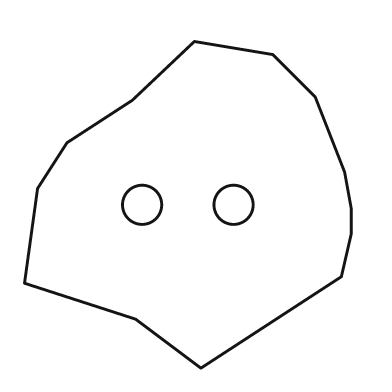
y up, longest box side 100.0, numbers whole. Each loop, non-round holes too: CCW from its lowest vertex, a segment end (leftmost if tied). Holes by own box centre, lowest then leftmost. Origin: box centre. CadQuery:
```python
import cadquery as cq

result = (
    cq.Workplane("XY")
    .moveTo(4.0, -50.0)
    .lineTo(47.0, -22.0)
    .lineTo(50.0, -9.0)
    .lineTo(50.0, -1.0)
    .lineTo(48.0, 10.0)
    .lineTo(39.0, 33.0)
    .lineTo(26.0, 46.0)
    .lineTo(2.0, 50.0)
    .lineTo(-17.0, 32.0)
    .lineTo(-37.0, 19.0)
    .lineTo(-46.0, 5.0)
    .lineTo(-50.0, -24.0)
    .lineTo(-16.0, -35.0)
    .close()
    .moveTo(-14.0, 0.0)
    .circle(6.0)
    .moveTo(14.0, 0.0)
    .circle(6.0)
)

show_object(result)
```